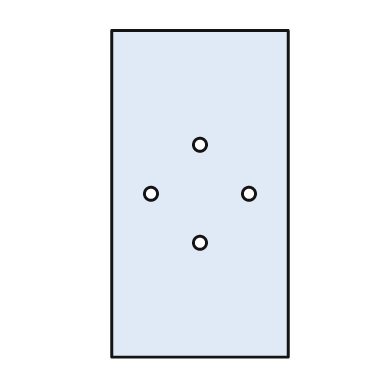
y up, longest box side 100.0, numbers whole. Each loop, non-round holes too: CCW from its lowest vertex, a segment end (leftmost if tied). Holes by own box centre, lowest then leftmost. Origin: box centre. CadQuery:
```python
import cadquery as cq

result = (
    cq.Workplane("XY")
    .moveTo(-27.0, -50.0)
    .lineTo(27.0, -50.0)
    .lineTo(27.0, 50.0)
    .lineTo(-27.0, 50.0)
    .close()
    .moveTo(0.0, -15.0)
    .circle(2.0)
    .moveTo(-15.0, 0.0)
    .circle(2.0)
    .moveTo(15.0, 0.0)
    .circle(2.0)
    .moveTo(0.0, 15.0)
    .circle(2.0)
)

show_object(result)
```